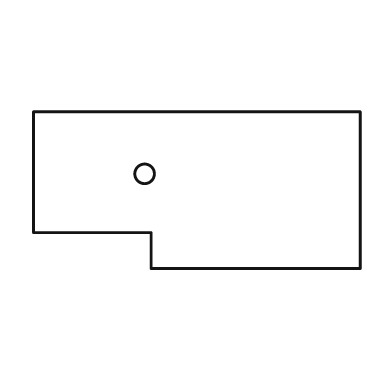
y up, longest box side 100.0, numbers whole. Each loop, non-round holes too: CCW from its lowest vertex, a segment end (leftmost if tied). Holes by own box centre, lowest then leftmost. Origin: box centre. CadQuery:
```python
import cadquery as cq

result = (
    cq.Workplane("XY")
    .moveTo(-14.0, -24.0)
    .lineTo(50.0, -24.0)
    .lineTo(50.0, 24.0)
    .lineTo(-50.0, 24.0)
    .lineTo(-50.0, -13.0)
    .lineTo(-14.0, -13.0)
    .close()
    .moveTo(-16.0, 5.0)
    .circle(3.0)
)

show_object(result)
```